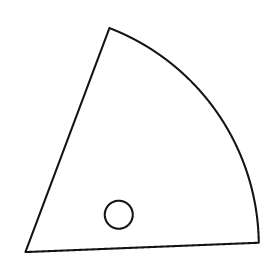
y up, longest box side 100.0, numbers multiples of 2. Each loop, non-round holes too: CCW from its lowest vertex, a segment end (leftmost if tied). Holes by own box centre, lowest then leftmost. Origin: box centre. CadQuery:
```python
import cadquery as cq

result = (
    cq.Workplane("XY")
    .moveTo(-50.0, -48.0)
    .lineTo(50.0, -44.0)
    .threePointArc((32.0, 12.0), (-14.0, 48.0))
    .close()
    .moveTo(-10.0, -32.0)
    .circle(6.0)
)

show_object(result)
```